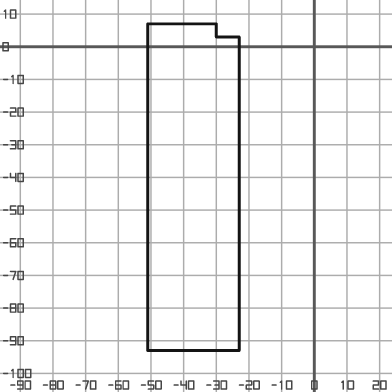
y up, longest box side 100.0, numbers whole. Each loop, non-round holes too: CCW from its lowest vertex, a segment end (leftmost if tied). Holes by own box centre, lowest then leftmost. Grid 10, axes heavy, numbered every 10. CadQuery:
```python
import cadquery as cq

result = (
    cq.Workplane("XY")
    .moveTo(-51.0, -93.0)
    .lineTo(-23.0, -93.0)
    .lineTo(-23.0, 3.0)
    .lineTo(-30.0, 3.0)
    .lineTo(-30.0, 7.0)
    .lineTo(-51.0, 7.0)
    .close()
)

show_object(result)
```